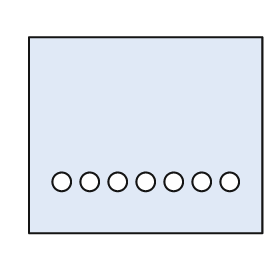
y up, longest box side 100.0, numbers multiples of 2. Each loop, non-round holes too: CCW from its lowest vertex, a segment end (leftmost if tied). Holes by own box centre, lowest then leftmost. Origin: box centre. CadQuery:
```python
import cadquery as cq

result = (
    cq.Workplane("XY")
    .moveTo(-50.0, -42.0)
    .lineTo(50.0, -42.0)
    .lineTo(50.0, 42.0)
    .lineTo(-50.0, 42.0)
    .close()
    .moveTo(-36.0, -20.0)
    .circle(4.0)
    .moveTo(-24.0, -20.0)
    .circle(4.0)
    .moveTo(-12.0, -20.0)
    .circle(4.0)
    .moveTo(0.0, -20.0)
    .circle(4.0)
    .moveTo(12.0, -20.0)
    .circle(4.0)
    .moveTo(24.0, -20.0)
    .circle(4.0)
    .moveTo(36.0, -20.0)
    .circle(4.0)
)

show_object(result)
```